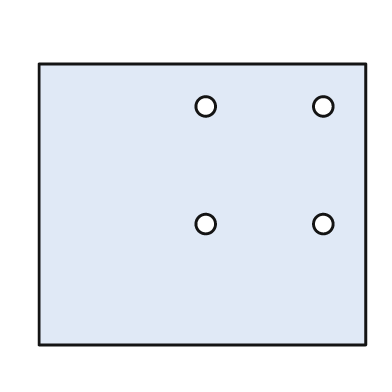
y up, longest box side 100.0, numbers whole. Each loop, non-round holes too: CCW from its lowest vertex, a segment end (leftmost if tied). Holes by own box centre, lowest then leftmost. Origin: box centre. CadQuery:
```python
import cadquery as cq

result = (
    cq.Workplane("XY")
    .moveTo(-50.0, -43.0)
    .lineTo(50.0, -43.0)
    .lineTo(50.0, 43.0)
    .lineTo(-50.0, 43.0)
    .close()
    .moveTo(1.0, -6.0)
    .circle(3.0)
    .moveTo(37.0, -6.0)
    .circle(3.0)
    .moveTo(1.0, 30.0)
    .circle(3.0)
    .moveTo(37.0, 30.0)
    .circle(3.0)
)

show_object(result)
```